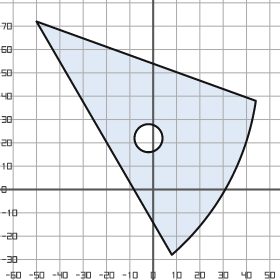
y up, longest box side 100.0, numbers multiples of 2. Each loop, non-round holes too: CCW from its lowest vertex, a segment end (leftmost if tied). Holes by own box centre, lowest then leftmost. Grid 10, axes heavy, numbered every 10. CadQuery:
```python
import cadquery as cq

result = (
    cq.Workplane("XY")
    .moveTo(8.0, -28.0)
    .threePointArc((32.0, 2.0), (44.0, 38.0))
    .lineTo(-50.0, 72.0)
    .close()
    .moveTo(-2.0, 22.0)
    .circle(6.0)
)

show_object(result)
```